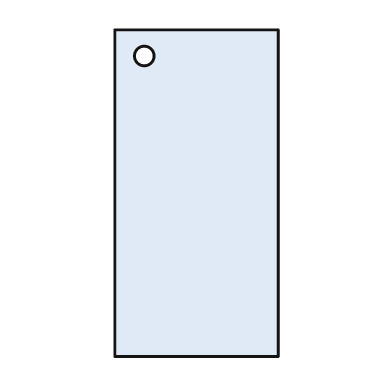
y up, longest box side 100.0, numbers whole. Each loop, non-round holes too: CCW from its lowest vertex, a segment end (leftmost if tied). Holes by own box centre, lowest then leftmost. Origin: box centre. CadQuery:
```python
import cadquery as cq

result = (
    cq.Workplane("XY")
    .moveTo(-25.0, -50.0)
    .lineTo(25.0, -50.0)
    .lineTo(25.0, 50.0)
    .lineTo(-25.0, 50.0)
    .close()
    .moveTo(-16.0, 42.0)
    .circle(3.0)
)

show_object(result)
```